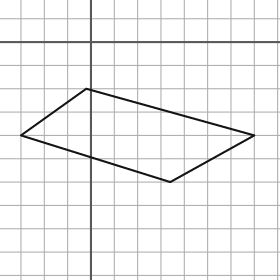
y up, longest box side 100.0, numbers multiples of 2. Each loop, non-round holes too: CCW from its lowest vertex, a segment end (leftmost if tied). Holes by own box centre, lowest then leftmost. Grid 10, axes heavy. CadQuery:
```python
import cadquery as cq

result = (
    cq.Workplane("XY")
    .moveTo(34.0, -60.0)
    .lineTo(70.0, -40.0)
    .lineTo(-2.0, -20.0)
    .lineTo(-30.0, -40.0)
    .close()
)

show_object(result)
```